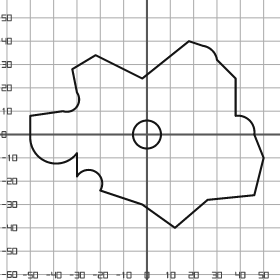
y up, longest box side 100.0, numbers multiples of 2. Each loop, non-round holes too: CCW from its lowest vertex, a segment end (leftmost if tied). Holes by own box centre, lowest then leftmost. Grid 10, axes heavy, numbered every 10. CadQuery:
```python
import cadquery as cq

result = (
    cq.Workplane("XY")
    .moveTo(12.0, -40.0)
    .lineTo(26.0, -28.0)
    .lineTo(46.0, -26.0)
    .lineTo(50.0, -10.0)
    .lineTo(46.0, 0.0)
    .threePointArc((44.0, 6.0), (38.0, 8.0))
    .lineTo(38.0, 24.0)
    .lineTo(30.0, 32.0)
    .threePointArc((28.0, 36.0), (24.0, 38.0))
    .lineTo(18.0, 40.0)
    .lineTo(-2.0, 24.0)
    .lineTo(-22.0, 34.0)
    .lineTo(-32.0, 28.0)
    .lineTo(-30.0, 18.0)
    .threePointArc((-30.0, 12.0), (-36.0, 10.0))
    .lineTo(-50.0, 8.0)
    .lineTo(-50.0, -2.0)
    .threePointArc((-42.0, -12.0), (-30.0, -8.0))
    .lineTo(-30.0, -18.0)
    .threePointArc((-22.0, -16.0), (-20.0, -24.0))
    .lineTo(-2.0, -30.0)
    .close()
    .moveTo(0.0, 0.0)
    .circle(6.0)
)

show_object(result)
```